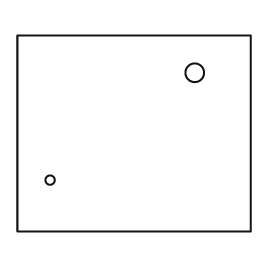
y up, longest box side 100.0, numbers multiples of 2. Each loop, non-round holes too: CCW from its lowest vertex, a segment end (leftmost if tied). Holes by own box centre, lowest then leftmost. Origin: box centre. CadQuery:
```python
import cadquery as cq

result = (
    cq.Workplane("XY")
    .moveTo(-50.0, -42.0)
    .lineTo(50.0, -42.0)
    .lineTo(50.0, 42.0)
    .lineTo(-50.0, 42.0)
    .close()
    .moveTo(-36.0, -20.0)
    .circle(2.0)
    .moveTo(26.0, 26.0)
    .circle(4.0)
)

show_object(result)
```